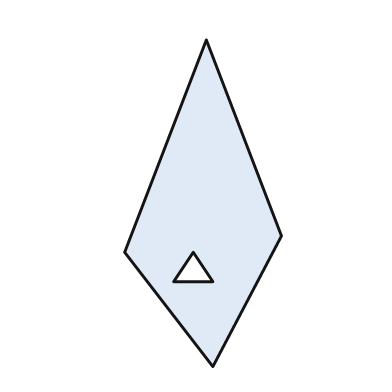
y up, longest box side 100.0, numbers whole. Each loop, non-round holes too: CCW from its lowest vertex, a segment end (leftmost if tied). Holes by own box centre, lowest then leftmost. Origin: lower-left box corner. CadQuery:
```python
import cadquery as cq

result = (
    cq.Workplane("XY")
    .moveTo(27.0, 0.0)
    .lineTo(48.0, 40.0)
    .lineTo(25.0, 100.0)
    .lineTo(0.0, 35.0)
    .close()
    .moveTo(15.0, 26.0)
    .lineTo(27.0, 26.0)
    .lineTo(21.0, 35.0)
    .close()
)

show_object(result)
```